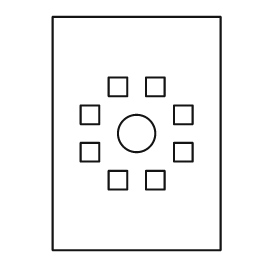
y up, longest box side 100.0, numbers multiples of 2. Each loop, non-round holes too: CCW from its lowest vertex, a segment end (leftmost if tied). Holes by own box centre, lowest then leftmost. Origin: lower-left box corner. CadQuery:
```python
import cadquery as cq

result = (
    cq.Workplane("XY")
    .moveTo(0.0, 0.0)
    .lineTo(72.0, 0.0)
    .lineTo(72.0, 100.0)
    .lineTo(0.0, 100.0)
    .close()
    .moveTo(24.0, 26.0)
    .lineTo(32.0, 26.0)
    .lineTo(32.0, 34.0)
    .lineTo(24.0, 34.0)
    .close()
    .moveTo(40.0, 26.0)
    .lineTo(48.0, 26.0)
    .lineTo(48.0, 34.0)
    .lineTo(40.0, 34.0)
    .close()
    .moveTo(12.0, 38.0)
    .lineTo(20.0, 38.0)
    .lineTo(20.0, 46.0)
    .lineTo(12.0, 46.0)
    .close()
    .moveTo(52.0, 38.0)
    .lineTo(60.0, 38.0)
    .lineTo(60.0, 46.0)
    .lineTo(52.0, 46.0)
    .close()
    .moveTo(36.0, 50.0)
    .circle(8.0)
    .moveTo(12.0, 54.0)
    .lineTo(20.0, 54.0)
    .lineTo(20.0, 62.0)
    .lineTo(12.0, 62.0)
    .close()
    .moveTo(52.0, 54.0)
    .lineTo(60.0, 54.0)
    .lineTo(60.0, 62.0)
    .lineTo(52.0, 62.0)
    .close()
    .moveTo(24.0, 66.0)
    .lineTo(32.0, 66.0)
    .lineTo(32.0, 74.0)
    .lineTo(24.0, 74.0)
    .close()
    .moveTo(40.0, 66.0)
    .lineTo(48.0, 66.0)
    .lineTo(48.0, 74.0)
    .lineTo(40.0, 74.0)
    .close()
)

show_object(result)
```